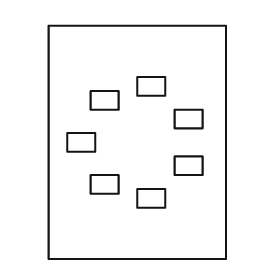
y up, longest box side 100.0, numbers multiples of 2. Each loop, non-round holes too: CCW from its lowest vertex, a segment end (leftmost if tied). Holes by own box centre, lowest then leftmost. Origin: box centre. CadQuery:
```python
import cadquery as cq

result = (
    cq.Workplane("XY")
    .moveTo(-38.0, -50.0)
    .lineTo(38.0, -50.0)
    .lineTo(38.0, 50.0)
    .lineTo(-38.0, 50.0)
    .close()
    .moveTo(0.0, -28.0)
    .lineTo(12.0, -28.0)
    .lineTo(12.0, -20.0)
    .lineTo(0.0, -20.0)
    .close()
    .moveTo(-20.0, -22.0)
    .lineTo(-8.0, -22.0)
    .lineTo(-8.0, -14.0)
    .lineTo(-20.0, -14.0)
    .close()
    .moveTo(16.0, -14.0)
    .lineTo(28.0, -14.0)
    .lineTo(28.0, -6.0)
    .lineTo(16.0, -6.0)
    .close()
    .moveTo(-30.0, -4.0)
    .lineTo(-18.0, -4.0)
    .lineTo(-18.0, 4.0)
    .lineTo(-30.0, 4.0)
    .close()
    .moveTo(16.0, 6.0)
    .lineTo(28.0, 6.0)
    .lineTo(28.0, 14.0)
    .lineTo(16.0, 14.0)
    .close()
    .moveTo(-20.0, 14.0)
    .lineTo(-8.0, 14.0)
    .lineTo(-8.0, 22.0)
    .lineTo(-20.0, 22.0)
    .close()
    .moveTo(0.0, 20.0)
    .lineTo(12.0, 20.0)
    .lineTo(12.0, 28.0)
    .lineTo(0.0, 28.0)
    .close()
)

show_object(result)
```